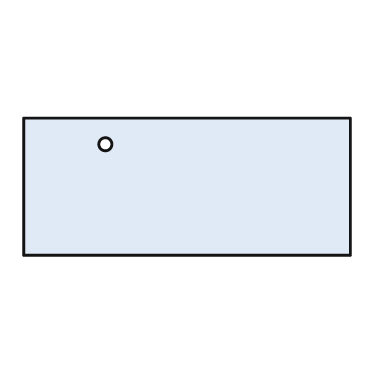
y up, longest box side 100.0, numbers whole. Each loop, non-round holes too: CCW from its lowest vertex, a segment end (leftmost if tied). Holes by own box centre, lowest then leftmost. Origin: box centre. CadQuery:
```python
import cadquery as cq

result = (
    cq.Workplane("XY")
    .moveTo(-50.0, -21.0)
    .lineTo(50.0, -21.0)
    .lineTo(50.0, 21.0)
    .lineTo(-50.0, 21.0)
    .close()
    .moveTo(-25.0, 13.0)
    .circle(2.0)
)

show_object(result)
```